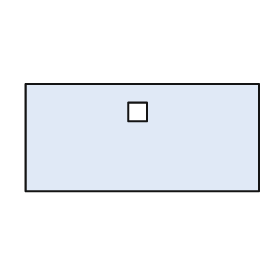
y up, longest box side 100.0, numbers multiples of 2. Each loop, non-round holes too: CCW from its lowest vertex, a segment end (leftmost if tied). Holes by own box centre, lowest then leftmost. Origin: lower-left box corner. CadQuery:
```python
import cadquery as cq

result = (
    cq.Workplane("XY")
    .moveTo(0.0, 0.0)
    .lineTo(100.0, 0.0)
    .lineTo(100.0, 46.0)
    .lineTo(0.0, 46.0)
    .close()
    .moveTo(44.0, 30.0)
    .lineTo(52.0, 30.0)
    .lineTo(52.0, 38.0)
    .lineTo(44.0, 38.0)
    .close()
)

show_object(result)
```